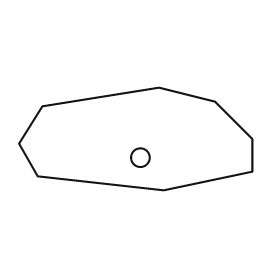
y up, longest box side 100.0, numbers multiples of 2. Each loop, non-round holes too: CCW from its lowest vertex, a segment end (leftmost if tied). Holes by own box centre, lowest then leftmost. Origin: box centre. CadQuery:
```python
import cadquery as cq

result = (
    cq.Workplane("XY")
    .moveTo(12.0, -22.0)
    .lineTo(50.0, -14.0)
    .lineTo(50.0, 0.0)
    .lineTo(34.0, 16.0)
    .lineTo(10.0, 22.0)
    .lineTo(-40.0, 14.0)
    .lineTo(-50.0, -2.0)
    .lineTo(-42.0, -16.0)
    .close()
    .moveTo(2.0, -8.0)
    .circle(4.0)
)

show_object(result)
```